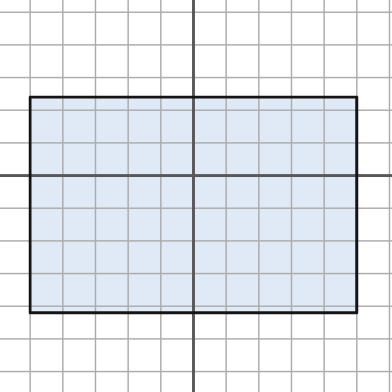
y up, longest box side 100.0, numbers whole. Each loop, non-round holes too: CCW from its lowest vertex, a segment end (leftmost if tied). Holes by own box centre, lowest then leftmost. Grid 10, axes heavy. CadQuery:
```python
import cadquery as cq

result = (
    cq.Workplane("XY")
    .moveTo(-50.0, -42.0)
    .lineTo(50.0, -42.0)
    .lineTo(50.0, 24.0)
    .lineTo(-50.0, 24.0)
    .close()
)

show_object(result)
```